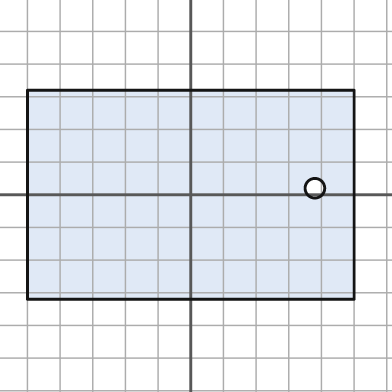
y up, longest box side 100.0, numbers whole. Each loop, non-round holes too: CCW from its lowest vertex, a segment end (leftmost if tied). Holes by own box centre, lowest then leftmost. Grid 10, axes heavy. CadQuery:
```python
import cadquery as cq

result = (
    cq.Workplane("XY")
    .moveTo(-50.0, -32.0)
    .lineTo(50.0, -32.0)
    .lineTo(50.0, 32.0)
    .lineTo(-50.0, 32.0)
    .close()
    .moveTo(38.0, 2.0)
    .circle(3.0)
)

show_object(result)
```